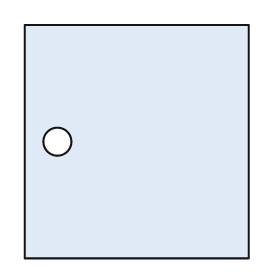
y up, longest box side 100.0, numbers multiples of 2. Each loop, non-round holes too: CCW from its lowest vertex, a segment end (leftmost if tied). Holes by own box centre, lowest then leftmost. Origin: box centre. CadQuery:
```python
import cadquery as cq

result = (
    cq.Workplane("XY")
    .moveTo(-48.0, -50.0)
    .lineTo(48.0, -50.0)
    .lineTo(48.0, 50.0)
    .lineTo(-48.0, 50.0)
    .close()
    .moveTo(-34.0, 0.0)
    .circle(6.0)
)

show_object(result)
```